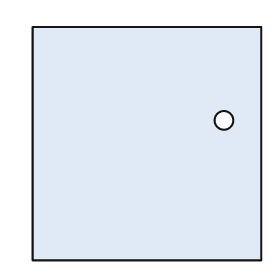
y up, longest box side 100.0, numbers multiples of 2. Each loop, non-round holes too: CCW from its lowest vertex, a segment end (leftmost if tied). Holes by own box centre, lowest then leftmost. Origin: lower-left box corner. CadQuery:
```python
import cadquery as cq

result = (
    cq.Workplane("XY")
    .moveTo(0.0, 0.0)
    .lineTo(98.0, 0.0)
    .lineTo(98.0, 100.0)
    .lineTo(0.0, 100.0)
    .close()
    .moveTo(82.0, 60.0)
    .circle(4.0)
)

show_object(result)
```